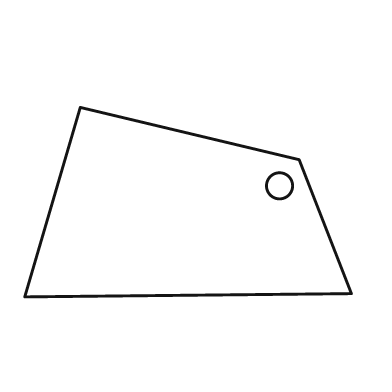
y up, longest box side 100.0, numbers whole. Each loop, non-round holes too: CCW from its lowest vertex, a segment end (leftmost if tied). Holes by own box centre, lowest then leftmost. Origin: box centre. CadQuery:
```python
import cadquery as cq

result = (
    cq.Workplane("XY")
    .moveTo(-50.0, -29.0)
    .lineTo(50.0, -28.0)
    .lineTo(34.0, 13.0)
    .lineTo(-33.0, 29.0)
    .close()
    .moveTo(28.0, 5.0)
    .circle(4.0)
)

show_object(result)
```